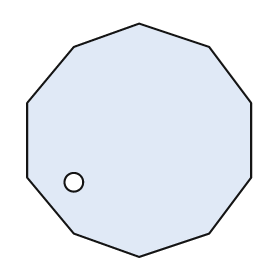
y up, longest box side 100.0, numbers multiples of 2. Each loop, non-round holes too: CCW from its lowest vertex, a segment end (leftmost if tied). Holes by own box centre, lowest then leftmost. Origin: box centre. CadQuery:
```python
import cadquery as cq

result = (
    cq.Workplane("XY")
    .moveTo(0.0, -50.0)
    .lineTo(30.0, -40.0)
    .lineTo(48.0, -16.0)
    .lineTo(48.0, 16.0)
    .lineTo(30.0, 40.0)
    .lineTo(0.0, 50.0)
    .lineTo(-28.0, 40.0)
    .lineTo(-48.0, 16.0)
    .lineTo(-48.0, -16.0)
    .lineTo(-28.0, -40.0)
    .close()
    .moveTo(-28.0, -18.0)
    .circle(4.0)
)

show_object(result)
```